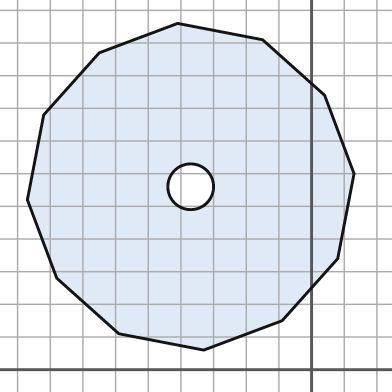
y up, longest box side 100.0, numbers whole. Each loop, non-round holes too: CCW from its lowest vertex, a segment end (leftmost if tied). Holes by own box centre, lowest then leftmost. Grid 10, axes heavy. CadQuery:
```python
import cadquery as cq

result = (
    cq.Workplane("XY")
    .moveTo(-33.0, 6.0)
    .lineTo(-9.0, 15.0)
    .lineTo(8.0, 34.0)
    .lineTo(13.0, 60.0)
    .lineTo(4.0, 84.0)
    .lineTo(-15.0, 101.0)
    .lineTo(-41.0, 106.0)
    .lineTo(-65.0, 97.0)
    .lineTo(-82.0, 78.0)
    .lineTo(-87.0, 52.0)
    .lineTo(-78.0, 28.0)
    .lineTo(-59.0, 11.0)
    .close()
    .moveTo(-37.0, 56.0)
    .circle(7.0)
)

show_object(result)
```